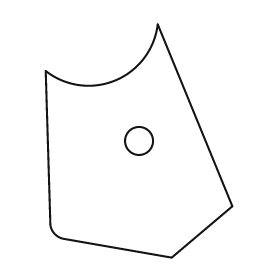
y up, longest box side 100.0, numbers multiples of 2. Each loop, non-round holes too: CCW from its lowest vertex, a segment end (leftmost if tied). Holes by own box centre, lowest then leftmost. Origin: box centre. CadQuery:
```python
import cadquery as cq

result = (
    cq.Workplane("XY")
    .moveTo(14.0, -50.0)
    .lineTo(40.0, -28.0)
    .lineTo(8.0, 50.0)
    .threePointArc((-10.0, 26.0), (-40.0, 30.0))
    .lineTo(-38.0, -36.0)
    .threePointArc((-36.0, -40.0), (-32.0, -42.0))
    .close()
    .moveTo(0.0, 0.0)
    .circle(6.0)
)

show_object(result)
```